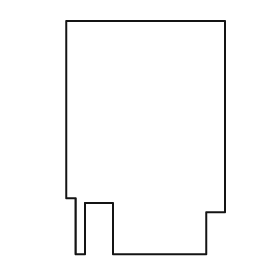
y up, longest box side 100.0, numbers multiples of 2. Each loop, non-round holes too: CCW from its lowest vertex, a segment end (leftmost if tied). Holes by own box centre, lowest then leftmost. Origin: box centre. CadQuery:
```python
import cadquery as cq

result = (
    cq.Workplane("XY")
    .moveTo(-30.0, -50.0)
    .lineTo(-26.0, -50.0)
    .lineTo(-26.0, -28.0)
    .lineTo(-14.0, -28.0)
    .lineTo(-14.0, -50.0)
    .lineTo(26.0, -50.0)
    .lineTo(26.0, -32.0)
    .lineTo(34.0, -32.0)
    .lineTo(34.0, 50.0)
    .lineTo(-34.0, 50.0)
    .lineTo(-34.0, -26.0)
    .lineTo(-30.0, -26.0)
    .close()
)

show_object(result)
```